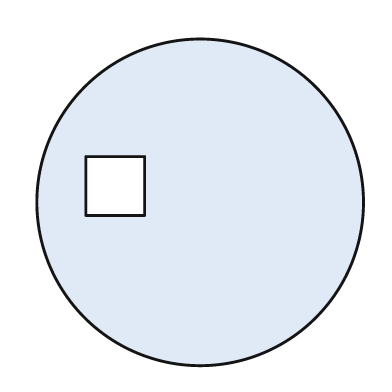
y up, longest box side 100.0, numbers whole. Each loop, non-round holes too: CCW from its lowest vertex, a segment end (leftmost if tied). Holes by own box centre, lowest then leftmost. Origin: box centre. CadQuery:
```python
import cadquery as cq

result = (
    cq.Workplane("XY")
    .moveTo(0.0, 0.0)
    .circle(50.0)
    .moveTo(-35.0, -4.0)
    .lineTo(-17.0, -4.0)
    .lineTo(-17.0, 14.0)
    .lineTo(-35.0, 14.0)
    .close()
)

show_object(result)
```